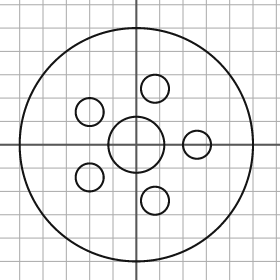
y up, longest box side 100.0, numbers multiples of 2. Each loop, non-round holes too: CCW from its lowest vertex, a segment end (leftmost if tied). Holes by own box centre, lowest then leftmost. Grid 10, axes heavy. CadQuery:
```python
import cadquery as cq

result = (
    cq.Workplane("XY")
    .moveTo(0.0, 0.0)
    .circle(50.0)
    .moveTo(8.0, -24.0)
    .circle(6.0)
    .moveTo(-20.0, -14.0)
    .circle(6.0)
    .moveTo(0.0, 0.0)
    .circle(12.0)
    .moveTo(26.0, 0.0)
    .circle(6.0)
    .moveTo(-20.0, 14.0)
    .circle(6.0)
    .moveTo(8.0, 24.0)
    .circle(6.0)
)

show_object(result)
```